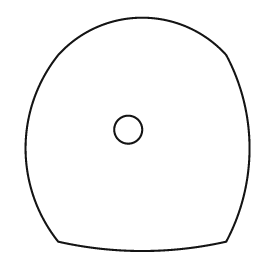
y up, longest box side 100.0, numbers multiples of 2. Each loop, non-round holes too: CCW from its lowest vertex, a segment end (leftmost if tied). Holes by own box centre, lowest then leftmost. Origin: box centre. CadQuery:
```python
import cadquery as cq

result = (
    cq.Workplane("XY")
    .moveTo(-34.0, -46.0)
    .threePointArc((2.0, -50.0), (38.0, -46.0))
    .threePointArc((48.0, -6.0), (38.0, 34.0))
    .threePointArc((2.0, 50.0), (-34.0, 34.0))
    .threePointArc((-48.0, -6.0), (-34.0, -46.0))
    .close()
    .moveTo(-4.0, 2.0)
    .circle(6.0)
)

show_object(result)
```